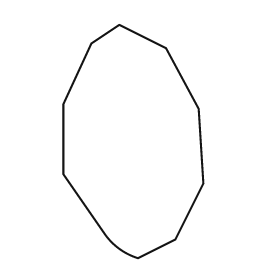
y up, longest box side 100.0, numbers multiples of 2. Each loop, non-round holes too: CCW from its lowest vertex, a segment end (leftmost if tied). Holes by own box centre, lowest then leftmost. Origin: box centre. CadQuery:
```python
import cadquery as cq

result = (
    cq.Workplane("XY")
    .moveTo(2.0, -50.0)
    .lineTo(18.0, -42.0)
    .lineTo(30.0, -18.0)
    .lineTo(28.0, 14.0)
    .lineTo(14.0, 40.0)
    .lineTo(-6.0, 50.0)
    .lineTo(-18.0, 42.0)
    .lineTo(-30.0, 16.0)
    .lineTo(-30.0, -14.0)
    .lineTo(-12.0, -40.0)
    .threePointArc((-6.0, -46.0), (2.0, -50.0))
    .close()
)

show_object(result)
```